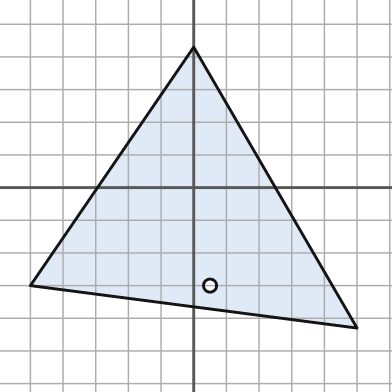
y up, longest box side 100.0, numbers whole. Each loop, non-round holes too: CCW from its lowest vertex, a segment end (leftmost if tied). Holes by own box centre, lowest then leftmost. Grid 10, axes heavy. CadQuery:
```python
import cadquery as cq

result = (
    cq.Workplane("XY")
    .moveTo(50.0, -43.0)
    .lineTo(0.0, 43.0)
    .lineTo(-50.0, -30.0)
    .close()
    .moveTo(5.0, -30.0)
    .circle(2.0)
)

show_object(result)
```